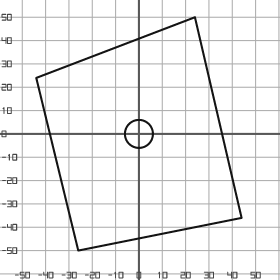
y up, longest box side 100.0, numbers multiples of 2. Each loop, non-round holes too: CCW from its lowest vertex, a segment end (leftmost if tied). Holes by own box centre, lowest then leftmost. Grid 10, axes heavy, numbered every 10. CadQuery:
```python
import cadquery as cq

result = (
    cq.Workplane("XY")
    .moveTo(-26.0, -50.0)
    .lineTo(44.0, -36.0)
    .lineTo(24.0, 50.0)
    .lineTo(-44.0, 24.0)
    .close()
    .moveTo(0.0, 0.0)
    .circle(6.0)
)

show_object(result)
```